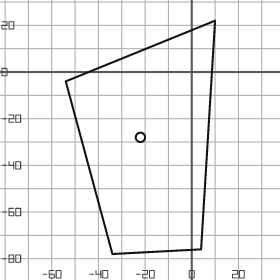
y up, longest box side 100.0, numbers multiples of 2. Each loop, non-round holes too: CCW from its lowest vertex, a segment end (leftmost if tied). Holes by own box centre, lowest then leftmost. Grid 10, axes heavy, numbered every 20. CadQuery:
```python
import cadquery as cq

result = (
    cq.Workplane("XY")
    .moveTo(-34.0, -78.0)
    .lineTo(4.0, -76.0)
    .lineTo(10.0, 22.0)
    .lineTo(-54.0, -4.0)
    .close()
    .moveTo(-22.0, -28.0)
    .circle(2.0)
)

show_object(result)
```